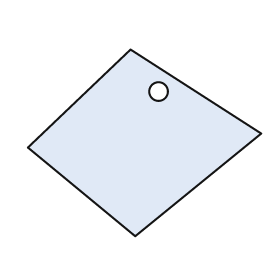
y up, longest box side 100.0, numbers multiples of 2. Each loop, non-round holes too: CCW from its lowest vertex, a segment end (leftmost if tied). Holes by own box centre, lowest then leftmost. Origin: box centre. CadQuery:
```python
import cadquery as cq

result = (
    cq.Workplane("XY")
    .moveTo(-4.0, -40.0)
    .lineTo(50.0, 4.0)
    .lineTo(-6.0, 40.0)
    .lineTo(-50.0, -2.0)
    .close()
    .moveTo(6.0, 22.0)
    .circle(4.0)
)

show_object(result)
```